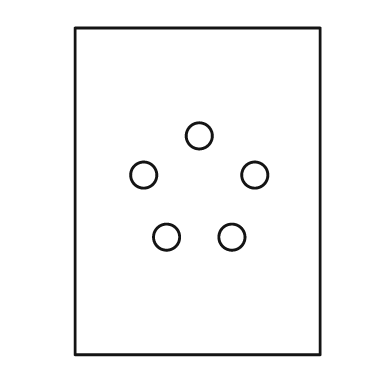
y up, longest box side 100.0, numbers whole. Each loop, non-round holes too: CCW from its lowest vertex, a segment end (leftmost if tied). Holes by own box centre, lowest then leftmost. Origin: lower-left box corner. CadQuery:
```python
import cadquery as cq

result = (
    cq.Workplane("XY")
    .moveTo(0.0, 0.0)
    .lineTo(75.0, 0.0)
    .lineTo(75.0, 100.0)
    .lineTo(0.0, 100.0)
    .close()
    .moveTo(28.0, 36.0)
    .circle(4.0)
    .moveTo(48.0, 36.0)
    .circle(4.0)
    .moveTo(21.0, 55.0)
    .circle(4.0)
    .moveTo(55.0, 55.0)
    .circle(4.0)
    .moveTo(38.0, 67.0)
    .circle(4.0)
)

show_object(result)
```